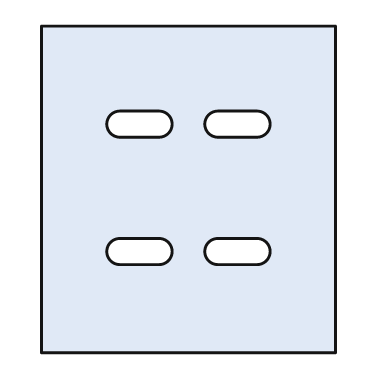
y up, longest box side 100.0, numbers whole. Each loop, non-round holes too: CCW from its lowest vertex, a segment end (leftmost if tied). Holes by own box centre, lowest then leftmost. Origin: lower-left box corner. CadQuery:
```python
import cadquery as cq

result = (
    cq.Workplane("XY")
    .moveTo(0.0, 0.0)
    .lineTo(90.0, 0.0)
    .lineTo(90.0, 100.0)
    .lineTo(0.0, 100.0)
    .close()
    .moveTo(24.0, 27.0)
    .lineTo(36.0, 27.0)
    .threePointArc((40.0, 31.0), (36.0, 35.0))
    .lineTo(24.0, 35.0)
    .threePointArc((20.0, 31.0), (24.0, 27.0))
    .close()
    .moveTo(54.0, 27.0)
    .lineTo(66.0, 27.0)
    .threePointArc((70.0, 31.0), (66.0, 35.0))
    .lineTo(54.0, 35.0)
    .threePointArc((50.0, 31.0), (54.0, 27.0))
    .close()
    .moveTo(24.0, 66.0)
    .lineTo(36.0, 66.0)
    .threePointArc((40.0, 70.0), (36.0, 74.0))
    .lineTo(24.0, 74.0)
    .threePointArc((20.0, 70.0), (24.0, 66.0))
    .close()
    .moveTo(54.0, 66.0)
    .lineTo(66.0, 66.0)
    .threePointArc((70.0, 70.0), (66.0, 74.0))
    .lineTo(54.0, 74.0)
    .threePointArc((50.0, 70.0), (54.0, 66.0))
    .close()
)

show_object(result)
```